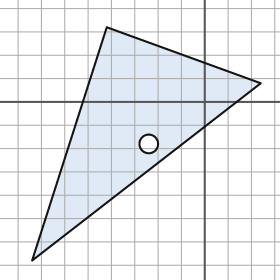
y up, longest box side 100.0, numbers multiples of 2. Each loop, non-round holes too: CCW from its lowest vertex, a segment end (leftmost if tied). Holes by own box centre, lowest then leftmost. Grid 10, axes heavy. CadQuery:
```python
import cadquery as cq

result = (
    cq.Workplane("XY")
    .moveTo(-74.0, -68.0)
    .lineTo(24.0, 8.0)
    .lineTo(-42.0, 32.0)
    .close()
    .moveTo(-24.0, -18.0)
    .circle(4.0)
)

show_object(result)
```